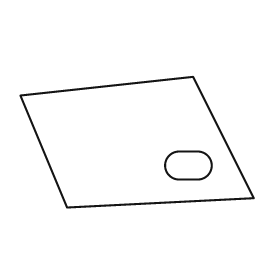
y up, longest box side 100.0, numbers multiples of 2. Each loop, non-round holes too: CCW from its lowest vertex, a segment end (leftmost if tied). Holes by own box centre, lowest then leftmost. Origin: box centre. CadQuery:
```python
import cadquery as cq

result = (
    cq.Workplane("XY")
    .moveTo(-30.0, -28.0)
    .lineTo(50.0, -24.0)
    .lineTo(24.0, 28.0)
    .lineTo(-50.0, 20.0)
    .close()
    .moveTo(18.0, -16.0)
    .lineTo(26.0, -16.0)
    .threePointArc((32.0, -10.0), (26.0, -4.0))
    .lineTo(18.0, -4.0)
    .threePointArc((12.0, -10.0), (18.0, -16.0))
    .close()
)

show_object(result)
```